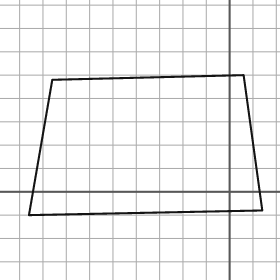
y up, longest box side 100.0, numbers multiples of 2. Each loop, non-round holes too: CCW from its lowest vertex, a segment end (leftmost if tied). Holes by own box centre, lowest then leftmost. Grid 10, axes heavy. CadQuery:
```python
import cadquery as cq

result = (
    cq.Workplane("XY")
    .moveTo(-86.0, -10.0)
    .lineTo(14.0, -8.0)
    .lineTo(6.0, 50.0)
    .lineTo(-76.0, 48.0)
    .close()
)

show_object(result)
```